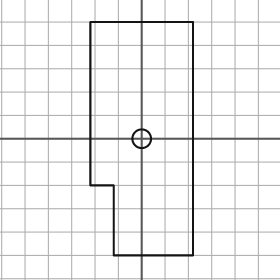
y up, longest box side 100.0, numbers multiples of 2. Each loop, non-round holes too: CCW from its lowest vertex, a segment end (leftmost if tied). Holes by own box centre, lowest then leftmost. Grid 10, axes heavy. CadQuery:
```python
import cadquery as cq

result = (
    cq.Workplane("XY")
    .moveTo(-12.0, -50.0)
    .lineTo(22.0, -50.0)
    .lineTo(22.0, 50.0)
    .lineTo(-22.0, 50.0)
    .lineTo(-22.0, -20.0)
    .lineTo(-12.0, -20.0)
    .close()
    .moveTo(0.0, 0.0)
    .circle(4.0)
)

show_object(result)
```